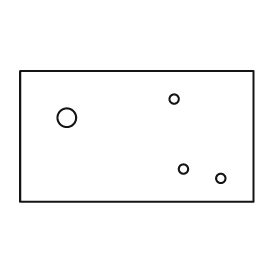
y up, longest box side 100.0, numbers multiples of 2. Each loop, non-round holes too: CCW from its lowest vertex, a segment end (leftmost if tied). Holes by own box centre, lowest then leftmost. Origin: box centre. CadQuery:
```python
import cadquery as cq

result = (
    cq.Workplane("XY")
    .moveTo(-50.0, -28.0)
    .lineTo(50.0, -28.0)
    .lineTo(50.0, 28.0)
    .lineTo(-50.0, 28.0)
    .close()
    .moveTo(36.0, -18.0)
    .circle(2.0)
    .moveTo(20.0, -14.0)
    .circle(2.0)
    .moveTo(-30.0, 8.0)
    .circle(4.0)
    .moveTo(16.0, 16.0)
    .circle(2.0)
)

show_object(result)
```